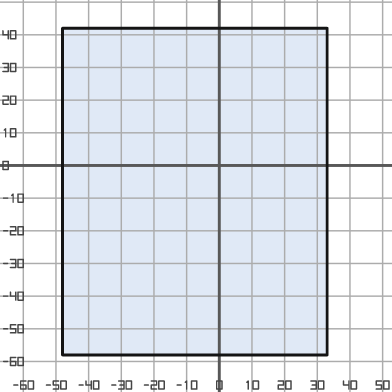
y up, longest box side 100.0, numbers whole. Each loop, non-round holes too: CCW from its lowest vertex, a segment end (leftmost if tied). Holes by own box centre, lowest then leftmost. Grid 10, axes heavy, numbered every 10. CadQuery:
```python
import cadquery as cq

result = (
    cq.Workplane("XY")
    .moveTo(-48.0, -58.0)
    .lineTo(33.0, -58.0)
    .lineTo(33.0, 42.0)
    .lineTo(-48.0, 42.0)
    .close()
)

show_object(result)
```